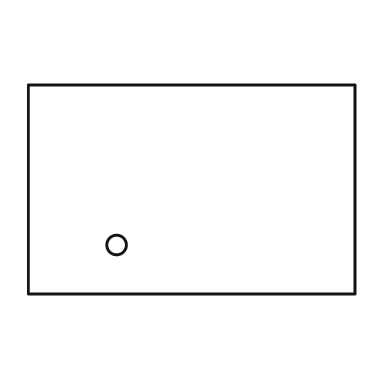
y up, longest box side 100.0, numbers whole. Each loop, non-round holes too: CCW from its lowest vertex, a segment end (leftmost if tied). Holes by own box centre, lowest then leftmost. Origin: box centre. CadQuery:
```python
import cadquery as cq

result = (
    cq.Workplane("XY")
    .moveTo(-50.0, -32.0)
    .lineTo(50.0, -32.0)
    .lineTo(50.0, 32.0)
    .lineTo(-50.0, 32.0)
    .close()
    .moveTo(-23.0, -17.0)
    .circle(3.0)
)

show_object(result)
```